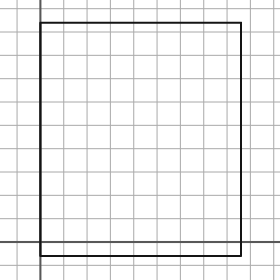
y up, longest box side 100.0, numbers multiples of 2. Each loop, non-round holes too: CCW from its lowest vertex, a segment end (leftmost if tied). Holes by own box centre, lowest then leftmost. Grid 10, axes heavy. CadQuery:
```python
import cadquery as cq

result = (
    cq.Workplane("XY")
    .moveTo(0.0, -6.0)
    .lineTo(86.0, -6.0)
    .lineTo(86.0, 94.0)
    .lineTo(0.0, 94.0)
    .close()
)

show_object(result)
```